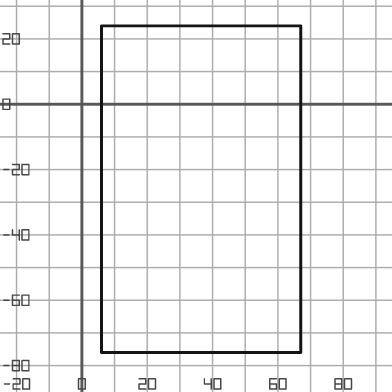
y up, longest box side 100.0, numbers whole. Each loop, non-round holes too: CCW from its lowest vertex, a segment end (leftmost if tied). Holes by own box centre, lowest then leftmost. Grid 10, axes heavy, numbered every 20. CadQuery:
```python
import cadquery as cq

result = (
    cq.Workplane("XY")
    .moveTo(6.0, -76.0)
    .lineTo(67.0, -76.0)
    .lineTo(67.0, 24.0)
    .lineTo(6.0, 24.0)
    .close()
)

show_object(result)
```